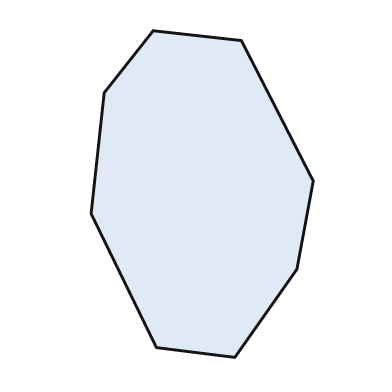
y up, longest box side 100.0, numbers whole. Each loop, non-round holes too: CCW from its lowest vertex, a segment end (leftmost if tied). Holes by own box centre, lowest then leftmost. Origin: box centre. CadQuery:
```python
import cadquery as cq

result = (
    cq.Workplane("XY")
    .moveTo(10.0, -50.0)
    .lineTo(29.0, -23.0)
    .lineTo(34.0, 4.0)
    .lineTo(12.0, 47.0)
    .lineTo(-15.0, 50.0)
    .lineTo(-30.0, 31.0)
    .lineTo(-34.0, -6.0)
    .lineTo(-14.0, -47.0)
    .close()
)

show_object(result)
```